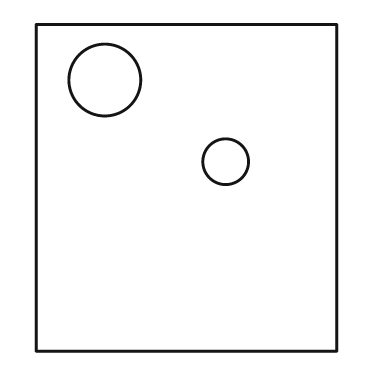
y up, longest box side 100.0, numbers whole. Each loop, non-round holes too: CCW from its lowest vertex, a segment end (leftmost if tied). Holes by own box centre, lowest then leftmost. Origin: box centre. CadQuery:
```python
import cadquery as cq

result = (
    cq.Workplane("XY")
    .moveTo(-46.0, -50.0)
    .lineTo(46.0, -50.0)
    .lineTo(46.0, 50.0)
    .lineTo(-46.0, 50.0)
    .close()
    .moveTo(12.0, 8.0)
    .circle(7.0)
    .moveTo(-25.0, 33.0)
    .circle(11.0)
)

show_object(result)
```